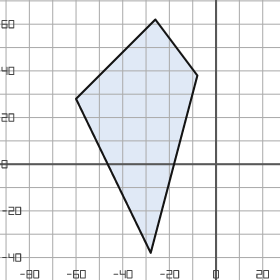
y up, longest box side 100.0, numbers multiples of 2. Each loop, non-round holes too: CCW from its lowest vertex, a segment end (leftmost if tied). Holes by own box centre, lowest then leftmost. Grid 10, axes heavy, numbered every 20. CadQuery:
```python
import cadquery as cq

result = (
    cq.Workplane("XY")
    .moveTo(-28.0, -38.0)
    .lineTo(-8.0, 38.0)
    .lineTo(-26.0, 62.0)
    .lineTo(-60.0, 28.0)
    .close()
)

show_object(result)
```